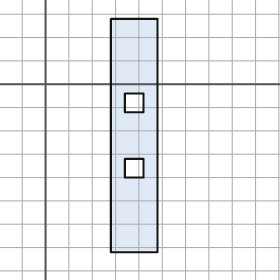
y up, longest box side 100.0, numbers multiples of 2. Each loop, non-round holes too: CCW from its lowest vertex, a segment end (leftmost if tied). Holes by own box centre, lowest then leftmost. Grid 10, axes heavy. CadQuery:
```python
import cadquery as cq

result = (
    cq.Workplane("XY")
    .moveTo(28.0, -72.0)
    .lineTo(48.0, -72.0)
    .lineTo(48.0, 28.0)
    .lineTo(28.0, 28.0)
    .close()
    .moveTo(34.0, -40.0)
    .lineTo(42.0, -40.0)
    .lineTo(42.0, -32.0)
    .lineTo(34.0, -32.0)
    .close()
    .moveTo(34.0, -12.0)
    .lineTo(42.0, -12.0)
    .lineTo(42.0, -4.0)
    .lineTo(34.0, -4.0)
    .close()
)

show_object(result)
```